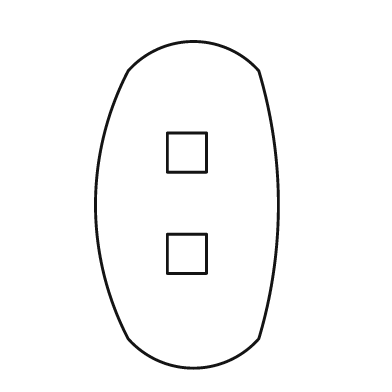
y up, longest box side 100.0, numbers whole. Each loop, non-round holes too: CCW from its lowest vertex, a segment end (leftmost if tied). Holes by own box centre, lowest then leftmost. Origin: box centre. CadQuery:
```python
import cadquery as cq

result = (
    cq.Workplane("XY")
    .moveTo(-18.0, -41.0)
    .threePointArc((2.0, -50.0), (22.0, -41.0))
    .threePointArc((28.0, 0.0), (22.0, 41.0))
    .threePointArc((2.0, 50.0), (-18.0, 41.0))
    .threePointArc((-28.0, 0.0), (-18.0, -41.0))
    .close()
    .moveTo(-6.0, -21.0)
    .lineTo(6.0, -21.0)
    .lineTo(6.0, -9.0)
    .lineTo(-6.0, -9.0)
    .close()
    .moveTo(-6.0, 10.0)
    .lineTo(6.0, 10.0)
    .lineTo(6.0, 22.0)
    .lineTo(-6.0, 22.0)
    .close()
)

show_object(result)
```